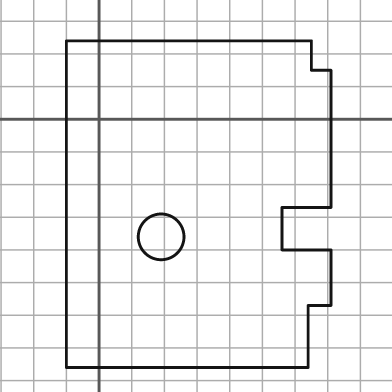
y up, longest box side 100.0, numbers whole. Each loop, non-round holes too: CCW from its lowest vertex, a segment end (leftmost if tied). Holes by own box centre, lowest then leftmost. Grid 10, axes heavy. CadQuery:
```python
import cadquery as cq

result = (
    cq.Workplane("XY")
    .moveTo(-10.0, -76.0)
    .lineTo(64.0, -76.0)
    .lineTo(64.0, -57.0)
    .lineTo(71.0, -57.0)
    .lineTo(71.0, -40.0)
    .lineTo(56.0, -40.0)
    .lineTo(56.0, -27.0)
    .lineTo(71.0, -27.0)
    .lineTo(71.0, 15.0)
    .lineTo(65.0, 15.0)
    .lineTo(65.0, 24.0)
    .lineTo(-10.0, 24.0)
    .close()
    .moveTo(19.0, -36.0)
    .circle(7.0)
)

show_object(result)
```